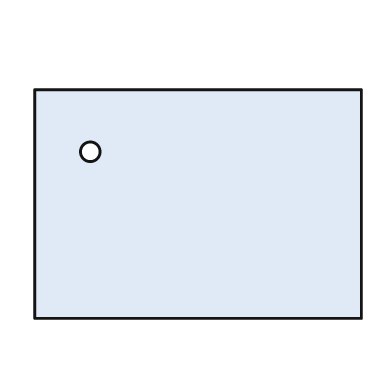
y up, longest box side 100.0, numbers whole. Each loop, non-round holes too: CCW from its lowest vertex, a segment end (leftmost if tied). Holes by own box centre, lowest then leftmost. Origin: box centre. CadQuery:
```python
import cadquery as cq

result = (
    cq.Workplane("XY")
    .moveTo(-50.0, -35.0)
    .lineTo(50.0, -35.0)
    .lineTo(50.0, 35.0)
    .lineTo(-50.0, 35.0)
    .close()
    .moveTo(-33.0, 16.0)
    .circle(3.0)
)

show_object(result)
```